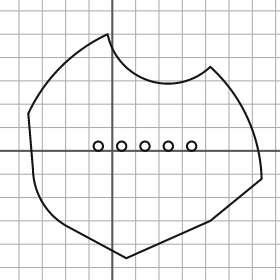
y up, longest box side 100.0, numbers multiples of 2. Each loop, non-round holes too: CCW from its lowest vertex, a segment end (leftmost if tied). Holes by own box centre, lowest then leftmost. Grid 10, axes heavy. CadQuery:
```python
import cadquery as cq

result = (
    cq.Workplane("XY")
    .moveTo(6.0, -46.0)
    .lineTo(42.0, -30.0)
    .lineTo(64.0, -12.0)
    .threePointArc((58.0, 14.0), (42.0, 36.0))
    .threePointArc((16.0, 30.0), (-2.0, 50.0))
    .threePointArc((-22.0, 36.0), (-36.0, 16.0))
    .lineTo(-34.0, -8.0)
    .threePointArc((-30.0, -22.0), (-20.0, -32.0))
    .close()
    .moveTo(-6.0, 2.0)
    .circle(2.0)
    .moveTo(4.0, 2.0)
    .circle(2.0)
    .moveTo(14.0, 2.0)
    .circle(2.0)
    .moveTo(24.0, 2.0)
    .circle(2.0)
    .moveTo(34.0, 2.0)
    .circle(2.0)
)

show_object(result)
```